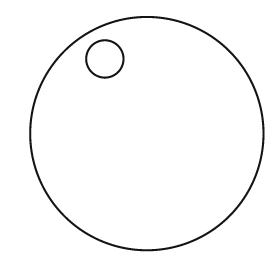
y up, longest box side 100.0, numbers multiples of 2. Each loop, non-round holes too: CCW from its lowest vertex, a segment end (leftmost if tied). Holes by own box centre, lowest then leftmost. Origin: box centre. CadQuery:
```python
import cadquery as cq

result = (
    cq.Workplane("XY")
    .moveTo(0.0, 0.0)
    .circle(50.0)
    .moveTo(-18.0, 32.0)
    .circle(8.0)
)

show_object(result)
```